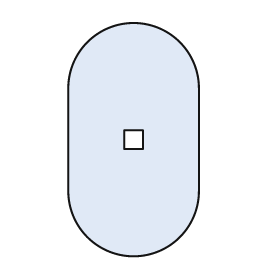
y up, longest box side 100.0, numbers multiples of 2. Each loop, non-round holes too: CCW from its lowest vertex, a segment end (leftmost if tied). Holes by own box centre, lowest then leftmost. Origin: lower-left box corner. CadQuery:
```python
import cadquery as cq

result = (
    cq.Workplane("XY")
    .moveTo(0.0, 28.0)
    .threePointArc((28.0, 0.0), (56.0, 28.0))
    .lineTo(56.0, 72.0)
    .threePointArc((28.0, 100.0), (0.0, 72.0))
    .close()
    .moveTo(24.0, 46.0)
    .lineTo(32.0, 46.0)
    .lineTo(32.0, 54.0)
    .lineTo(24.0, 54.0)
    .close()
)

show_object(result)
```